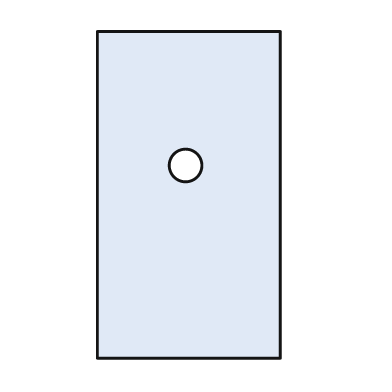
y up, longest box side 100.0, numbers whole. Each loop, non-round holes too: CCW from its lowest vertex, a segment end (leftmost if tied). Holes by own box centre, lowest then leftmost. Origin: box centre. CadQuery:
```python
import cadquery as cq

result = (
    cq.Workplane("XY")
    .moveTo(-28.0, -50.0)
    .lineTo(28.0, -50.0)
    .lineTo(28.0, 50.0)
    .lineTo(-28.0, 50.0)
    .close()
    .moveTo(-1.0, 9.0)
    .circle(5.0)
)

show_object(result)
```